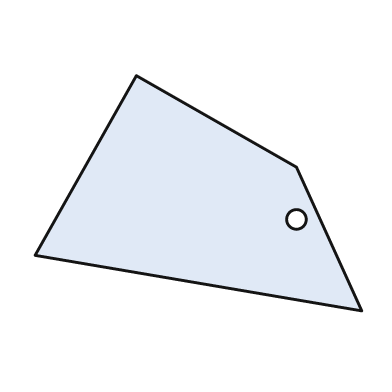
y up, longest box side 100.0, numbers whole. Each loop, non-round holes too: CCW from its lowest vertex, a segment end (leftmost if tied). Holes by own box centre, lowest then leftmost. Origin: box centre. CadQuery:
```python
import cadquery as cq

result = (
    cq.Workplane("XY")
    .moveTo(50.0, -36.0)
    .lineTo(30.0, 8.0)
    .lineTo(-19.0, 36.0)
    .lineTo(-50.0, -19.0)
    .close()
    .moveTo(30.0, -8.0)
    .circle(3.0)
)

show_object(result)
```